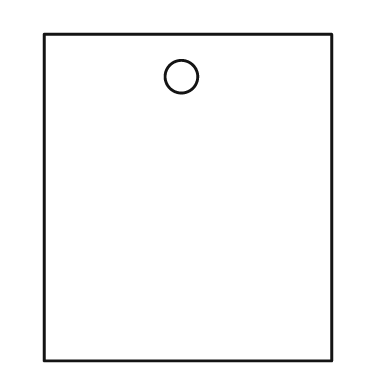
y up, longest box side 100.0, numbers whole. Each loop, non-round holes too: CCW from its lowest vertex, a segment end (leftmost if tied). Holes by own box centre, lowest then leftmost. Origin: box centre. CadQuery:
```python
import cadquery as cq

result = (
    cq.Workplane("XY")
    .moveTo(-44.0, -50.0)
    .lineTo(44.0, -50.0)
    .lineTo(44.0, 50.0)
    .lineTo(-44.0, 50.0)
    .close()
    .moveTo(-2.0, 37.0)
    .circle(5.0)
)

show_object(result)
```